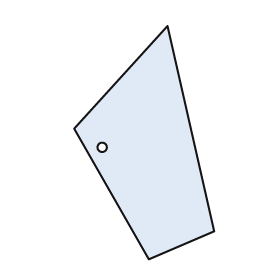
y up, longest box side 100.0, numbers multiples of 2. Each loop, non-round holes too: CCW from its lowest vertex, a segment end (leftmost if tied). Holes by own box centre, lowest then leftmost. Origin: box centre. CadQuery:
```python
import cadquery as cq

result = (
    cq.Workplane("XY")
    .moveTo(2.0, -50.0)
    .lineTo(30.0, -38.0)
    .lineTo(10.0, 50.0)
    .lineTo(-30.0, 6.0)
    .close()
    .moveTo(-18.0, -2.0)
    .circle(2.0)
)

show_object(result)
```